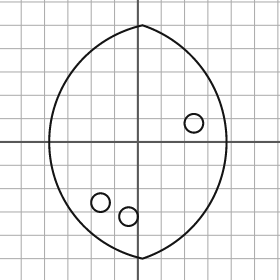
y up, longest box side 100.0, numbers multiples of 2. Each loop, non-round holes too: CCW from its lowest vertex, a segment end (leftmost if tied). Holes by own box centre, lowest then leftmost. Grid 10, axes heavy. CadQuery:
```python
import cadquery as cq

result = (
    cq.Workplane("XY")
    .moveTo(2.0, -50.0)
    .threePointArc((38.0, 0.0), (2.0, 50.0))
    .threePointArc((-38.0, 0.0), (2.0, -50.0))
    .close()
    .moveTo(-4.0, -32.0)
    .circle(4.0)
    .moveTo(-16.0, -26.0)
    .circle(4.0)
    .moveTo(24.0, 8.0)
    .circle(4.0)
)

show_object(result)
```